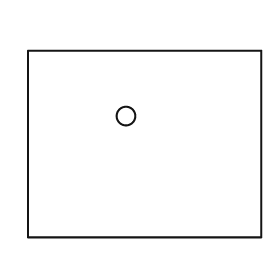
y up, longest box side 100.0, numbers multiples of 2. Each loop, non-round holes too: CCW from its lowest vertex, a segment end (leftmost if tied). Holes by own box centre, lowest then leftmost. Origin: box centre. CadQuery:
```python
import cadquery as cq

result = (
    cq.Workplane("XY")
    .moveTo(-50.0, -40.0)
    .lineTo(50.0, -40.0)
    .lineTo(50.0, 40.0)
    .lineTo(-50.0, 40.0)
    .close()
    .moveTo(-8.0, 12.0)
    .circle(4.0)
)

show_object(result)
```